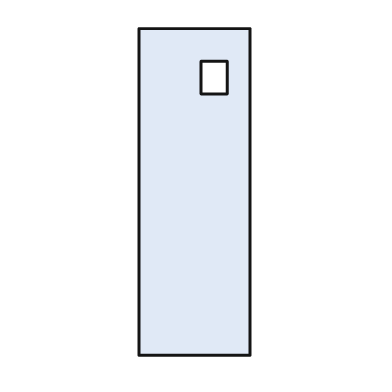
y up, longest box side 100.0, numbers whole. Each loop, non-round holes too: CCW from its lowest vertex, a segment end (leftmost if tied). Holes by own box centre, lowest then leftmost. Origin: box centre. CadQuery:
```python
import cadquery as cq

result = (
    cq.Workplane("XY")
    .moveTo(-17.0, -50.0)
    .lineTo(17.0, -50.0)
    .lineTo(17.0, 50.0)
    .lineTo(-17.0, 50.0)
    .close()
    .moveTo(2.0, 30.0)
    .lineTo(10.0, 30.0)
    .lineTo(10.0, 40.0)
    .lineTo(2.0, 40.0)
    .close()
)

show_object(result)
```